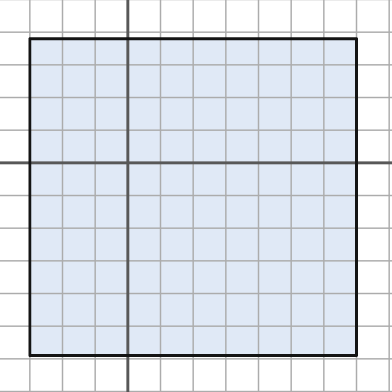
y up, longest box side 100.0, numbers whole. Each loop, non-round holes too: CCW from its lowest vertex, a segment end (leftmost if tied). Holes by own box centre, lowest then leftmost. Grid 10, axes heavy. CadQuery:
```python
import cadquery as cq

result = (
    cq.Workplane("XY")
    .moveTo(-30.0, -59.0)
    .lineTo(70.0, -59.0)
    .lineTo(70.0, 38.0)
    .lineTo(-30.0, 38.0)
    .close()
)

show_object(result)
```